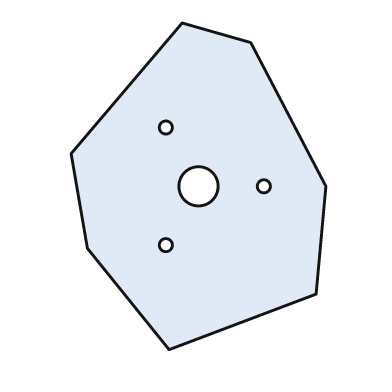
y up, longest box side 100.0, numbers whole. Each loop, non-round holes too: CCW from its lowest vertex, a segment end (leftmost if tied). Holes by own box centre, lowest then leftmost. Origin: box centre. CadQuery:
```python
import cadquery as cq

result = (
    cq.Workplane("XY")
    .moveTo(-9.0, -50.0)
    .lineTo(36.0, -33.0)
    .lineTo(39.0, 0.0)
    .lineTo(16.0, 44.0)
    .lineTo(-5.0, 50.0)
    .lineTo(-39.0, 10.0)
    .lineTo(-34.0, -19.0)
    .close()
    .moveTo(-10.0, -18.0)
    .circle(2.0)
    .moveTo(0.0, 0.0)
    .circle(6.0)
    .moveTo(20.0, 0.0)
    .circle(2.0)
    .moveTo(-10.0, 18.0)
    .circle(2.0)
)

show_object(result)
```